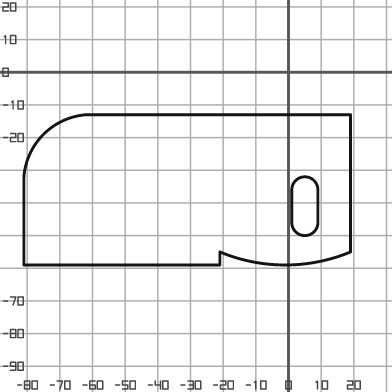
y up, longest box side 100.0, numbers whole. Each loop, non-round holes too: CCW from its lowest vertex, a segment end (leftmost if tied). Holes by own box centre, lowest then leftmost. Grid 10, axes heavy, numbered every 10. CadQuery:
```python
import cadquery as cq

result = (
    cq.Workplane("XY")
    .moveTo(-81.0, -59.0)
    .lineTo(-21.0, -59.0)
    .lineTo(-21.0, -55.0)
    .threePointArc((-1.0, -59.0), (19.0, -55.0))
    .lineTo(19.0, -13.0)
    .lineTo(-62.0, -13.0)
    .threePointArc((-75.0, -19.0), (-81.0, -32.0))
    .close()
    .moveTo(1.0, -46.0)
    .threePointArc((5.0, -50.0), (9.0, -46.0))
    .lineTo(9.0, -36.0)
    .threePointArc((5.0, -32.0), (1.0, -36.0))
    .close()
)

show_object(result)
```